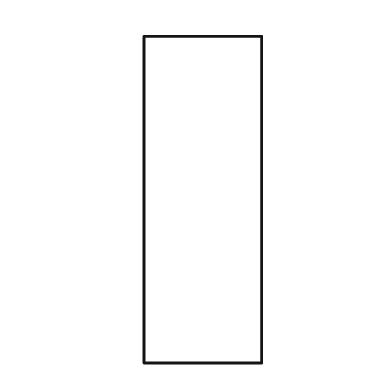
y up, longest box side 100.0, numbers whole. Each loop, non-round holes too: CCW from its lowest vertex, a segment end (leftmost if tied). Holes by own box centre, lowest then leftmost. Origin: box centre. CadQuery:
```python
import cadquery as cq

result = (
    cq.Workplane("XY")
    .moveTo(-18.0, -50.0)
    .lineTo(18.0, -50.0)
    .lineTo(18.0, 50.0)
    .lineTo(-18.0, 50.0)
    .close()
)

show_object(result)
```